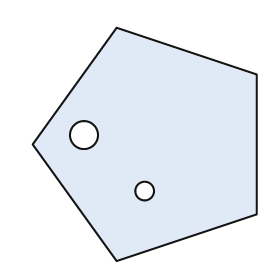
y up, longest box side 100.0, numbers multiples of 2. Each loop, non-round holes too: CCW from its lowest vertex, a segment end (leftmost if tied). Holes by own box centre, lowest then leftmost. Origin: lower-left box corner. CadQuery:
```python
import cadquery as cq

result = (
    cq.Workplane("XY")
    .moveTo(36.0, 0.0)
    .lineTo(96.0, 20.0)
    .lineTo(96.0, 80.0)
    .lineTo(36.0, 100.0)
    .lineTo(0.0, 50.0)
    .close()
    .moveTo(48.0, 30.0)
    .circle(4.0)
    .moveTo(22.0, 54.0)
    .circle(6.0)
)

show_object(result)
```